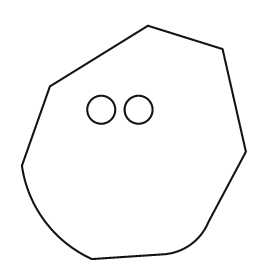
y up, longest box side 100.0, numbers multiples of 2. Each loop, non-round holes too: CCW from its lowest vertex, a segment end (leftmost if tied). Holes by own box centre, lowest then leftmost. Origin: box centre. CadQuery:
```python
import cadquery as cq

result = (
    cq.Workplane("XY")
    .moveTo(-18.0, -50.0)
    .lineTo(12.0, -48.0)
    .threePointArc((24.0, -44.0), (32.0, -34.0))
    .lineTo(48.0, -4.0)
    .lineTo(38.0, 40.0)
    .lineTo(6.0, 50.0)
    .lineTo(-36.0, 24.0)
    .lineTo(-48.0, -10.0)
    .threePointArc((-38.0, -34.0), (-18.0, -50.0))
    .close()
    .moveTo(-14.0, 14.0)
    .circle(6.0)
    .moveTo(2.0, 14.0)
    .circle(6.0)
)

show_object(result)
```